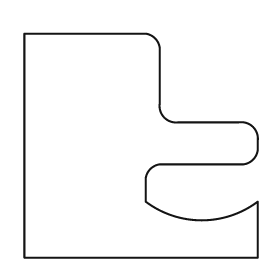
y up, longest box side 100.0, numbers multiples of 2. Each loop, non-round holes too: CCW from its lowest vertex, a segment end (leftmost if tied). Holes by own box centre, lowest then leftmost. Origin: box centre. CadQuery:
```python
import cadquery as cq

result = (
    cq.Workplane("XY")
    .moveTo(-50.0, -48.0)
    .lineTo(50.0, -48.0)
    .lineTo(50.0, -24.0)
    .threePointArc((26.0, -32.0), (2.0, -24.0))
    .lineTo(2.0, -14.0)
    .threePointArc((4.0, -10.0), (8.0, -8.0))
    .lineTo(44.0, -8.0)
    .threePointArc((48.0, -6.0), (50.0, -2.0))
    .lineTo(50.0, 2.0)
    .threePointArc((48.0, 8.0), (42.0, 10.0))
    .lineTo(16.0, 10.0)
    .threePointArc((10.0, 12.0), (8.0, 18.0))
    .lineTo(8.0, 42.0)
    .threePointArc((6.0, 46.0), (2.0, 48.0))
    .lineTo(-50.0, 48.0)
    .close()
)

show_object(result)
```